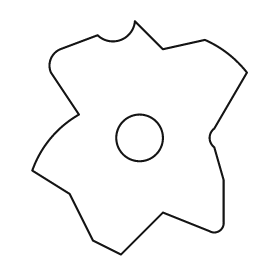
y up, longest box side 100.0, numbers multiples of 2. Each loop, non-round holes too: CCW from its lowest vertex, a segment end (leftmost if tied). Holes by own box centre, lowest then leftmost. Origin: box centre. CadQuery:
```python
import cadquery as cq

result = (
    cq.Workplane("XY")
    .moveTo(-8.0, -50.0)
    .lineTo(10.0, -32.0)
    .lineTo(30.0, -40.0)
    .threePointArc((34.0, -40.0), (36.0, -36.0))
    .lineTo(36.0, -18.0)
    .lineTo(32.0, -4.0)
    .threePointArc((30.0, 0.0), (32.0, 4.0))
    .lineTo(46.0, 28.0)
    .threePointArc((38.0, 36.0), (28.0, 42.0))
    .lineTo(10.0, 38.0)
    .lineTo(-2.0, 50.0)
    .threePointArc((-8.0, 42.0), (-18.0, 44.0))
    .lineTo(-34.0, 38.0)
    .threePointArc((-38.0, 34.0), (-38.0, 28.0))
    .lineTo(-26.0, 10.0)
    .threePointArc((-38.0, 0.0), (-46.0, -14.0))
    .lineTo(-30.0, -24.0)
    .lineTo(-20.0, -44.0)
    .close()
    .moveTo(0.0, 0.0)
    .circle(10.0)
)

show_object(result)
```